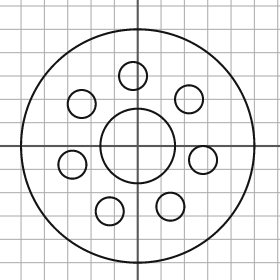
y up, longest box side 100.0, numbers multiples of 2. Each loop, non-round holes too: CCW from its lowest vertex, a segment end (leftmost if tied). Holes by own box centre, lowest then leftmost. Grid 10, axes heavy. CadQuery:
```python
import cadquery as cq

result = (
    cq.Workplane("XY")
    .moveTo(0.0, 0.0)
    .circle(50.0)
    .moveTo(-12.0, -28.0)
    .circle(6.0)
    .moveTo(14.0, -26.0)
    .circle(6.0)
    .moveTo(-28.0, -8.0)
    .circle(6.0)
    .moveTo(28.0, -6.0)
    .circle(6.0)
    .moveTo(0.0, 0.0)
    .circle(16.0)
    .moveTo(-24.0, 18.0)
    .circle(6.0)
    .moveTo(22.0, 20.0)
    .circle(6.0)
    .moveTo(-2.0, 30.0)
    .circle(6.0)
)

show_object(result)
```